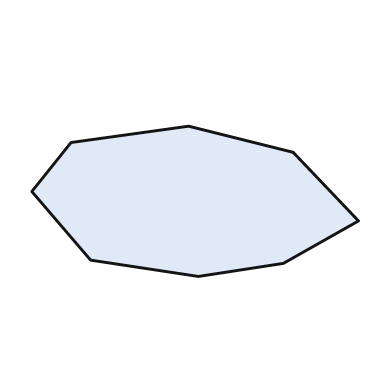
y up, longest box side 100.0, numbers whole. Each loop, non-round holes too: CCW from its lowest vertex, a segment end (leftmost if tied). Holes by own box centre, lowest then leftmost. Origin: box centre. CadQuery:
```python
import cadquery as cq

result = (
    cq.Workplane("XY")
    .moveTo(1.0, -23.0)
    .lineTo(27.0, -19.0)
    .lineTo(50.0, -6.0)
    .lineTo(30.0, 15.0)
    .lineTo(-2.0, 23.0)
    .lineTo(-38.0, 18.0)
    .lineTo(-50.0, 3.0)
    .lineTo(-32.0, -18.0)
    .close()
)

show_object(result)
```